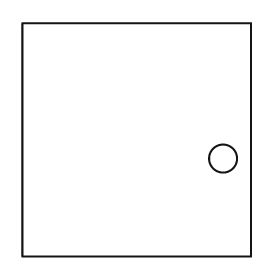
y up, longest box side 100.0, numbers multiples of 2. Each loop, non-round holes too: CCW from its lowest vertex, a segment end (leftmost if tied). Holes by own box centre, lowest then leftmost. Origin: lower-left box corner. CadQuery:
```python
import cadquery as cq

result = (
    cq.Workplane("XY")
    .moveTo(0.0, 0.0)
    .lineTo(98.0, 0.0)
    .lineTo(98.0, 100.0)
    .lineTo(0.0, 100.0)
    .close()
    .moveTo(86.0, 42.0)
    .circle(6.0)
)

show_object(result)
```